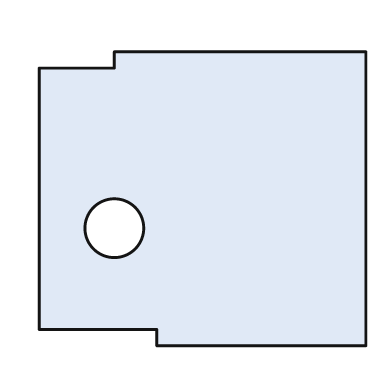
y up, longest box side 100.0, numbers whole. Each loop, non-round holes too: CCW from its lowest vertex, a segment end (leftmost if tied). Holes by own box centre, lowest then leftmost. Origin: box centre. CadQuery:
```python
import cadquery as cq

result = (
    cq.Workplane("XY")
    .moveTo(-14.0, -45.0)
    .lineTo(50.0, -45.0)
    .lineTo(50.0, 45.0)
    .lineTo(-27.0, 45.0)
    .lineTo(-27.0, 40.0)
    .lineTo(-50.0, 40.0)
    .lineTo(-50.0, -40.0)
    .lineTo(-14.0, -40.0)
    .close()
    .moveTo(-27.0, -9.0)
    .circle(9.0)
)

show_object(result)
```